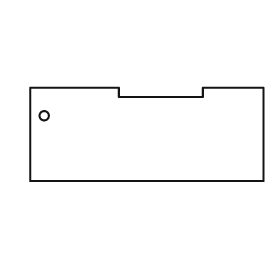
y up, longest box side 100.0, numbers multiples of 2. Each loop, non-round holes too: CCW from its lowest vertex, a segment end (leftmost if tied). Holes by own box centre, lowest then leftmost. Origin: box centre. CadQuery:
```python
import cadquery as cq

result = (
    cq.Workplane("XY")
    .moveTo(-50.0, -20.0)
    .lineTo(50.0, -20.0)
    .lineTo(50.0, 20.0)
    .lineTo(24.0, 20.0)
    .lineTo(24.0, 16.0)
    .lineTo(-12.0, 16.0)
    .lineTo(-12.0, 20.0)
    .lineTo(-50.0, 20.0)
    .close()
    .moveTo(-44.0, 8.0)
    .circle(2.0)
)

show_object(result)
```